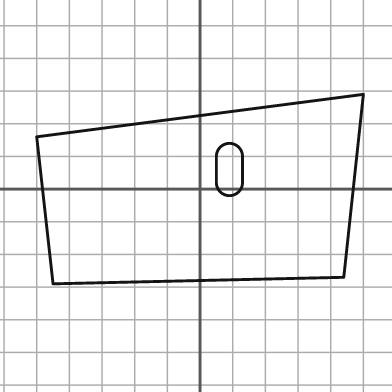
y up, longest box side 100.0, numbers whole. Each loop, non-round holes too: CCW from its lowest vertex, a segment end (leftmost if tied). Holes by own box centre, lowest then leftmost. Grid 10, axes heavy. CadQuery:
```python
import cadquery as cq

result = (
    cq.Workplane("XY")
    .moveTo(-45.0, -29.0)
    .lineTo(44.0, -27.0)
    .lineTo(50.0, 29.0)
    .lineTo(-50.0, 16.0)
    .close()
    .moveTo(5.0, 2.0)
    .threePointArc((9.0, -2.0), (13.0, 2.0))
    .lineTo(13.0, 10.0)
    .threePointArc((9.0, 14.0), (5.0, 10.0))
    .close()
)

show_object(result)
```